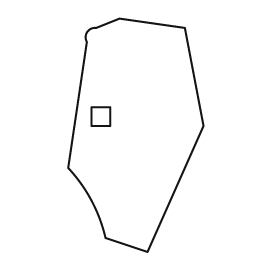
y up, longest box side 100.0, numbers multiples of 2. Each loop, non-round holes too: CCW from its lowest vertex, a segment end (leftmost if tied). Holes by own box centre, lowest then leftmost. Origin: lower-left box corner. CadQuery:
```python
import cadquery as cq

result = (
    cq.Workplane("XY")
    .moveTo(34.0, 0.0)
    .lineTo(58.0, 54.0)
    .lineTo(50.0, 96.0)
    .lineTo(22.0, 100.0)
    .lineTo(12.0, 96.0)
    .threePointArc((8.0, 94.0), (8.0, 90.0))
    .lineTo(0.0, 36.0)
    .threePointArc((10.0, 22.0), (16.0, 6.0))
    .close()
    .moveTo(10.0, 54.0)
    .lineTo(18.0, 54.0)
    .lineTo(18.0, 62.0)
    .lineTo(10.0, 62.0)
    .close()
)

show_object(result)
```